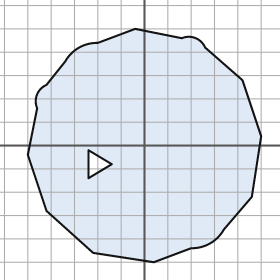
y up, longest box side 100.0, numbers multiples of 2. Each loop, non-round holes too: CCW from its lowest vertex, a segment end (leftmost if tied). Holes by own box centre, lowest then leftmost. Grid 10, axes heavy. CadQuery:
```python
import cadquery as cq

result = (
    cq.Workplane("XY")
    .moveTo(4.0, -50.0)
    .lineTo(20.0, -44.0)
    .threePointArc((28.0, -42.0), (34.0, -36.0))
    .lineTo(46.0, -22.0)
    .lineTo(50.0, 4.0)
    .lineTo(42.0, 28.0)
    .lineTo(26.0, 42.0)
    .threePointArc((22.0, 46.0), (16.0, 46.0))
    .lineTo(-4.0, 50.0)
    .lineTo(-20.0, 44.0)
    .threePointArc((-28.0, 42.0), (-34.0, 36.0))
    .lineTo(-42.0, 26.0)
    .threePointArc((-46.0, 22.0), (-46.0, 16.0))
    .lineTo(-50.0, -4.0)
    .lineTo(-42.0, -28.0)
    .lineTo(-22.0, -46.0)
    .close()
    .moveTo(-24.0, -14.0)
    .lineTo(-14.0, -8.0)
    .lineTo(-24.0, -2.0)
    .close()
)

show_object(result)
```